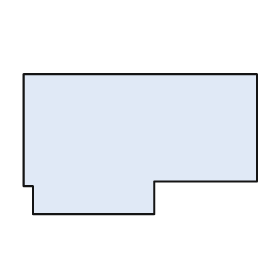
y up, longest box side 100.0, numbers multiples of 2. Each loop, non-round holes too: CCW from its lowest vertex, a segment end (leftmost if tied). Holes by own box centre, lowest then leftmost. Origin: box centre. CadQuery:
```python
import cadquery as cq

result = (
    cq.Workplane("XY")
    .moveTo(-46.0, -30.0)
    .lineTo(6.0, -30.0)
    .lineTo(6.0, -16.0)
    .lineTo(50.0, -16.0)
    .lineTo(50.0, 30.0)
    .lineTo(-50.0, 30.0)
    .lineTo(-50.0, -18.0)
    .lineTo(-46.0, -18.0)
    .close()
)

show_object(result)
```